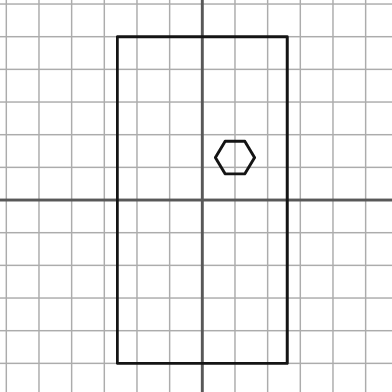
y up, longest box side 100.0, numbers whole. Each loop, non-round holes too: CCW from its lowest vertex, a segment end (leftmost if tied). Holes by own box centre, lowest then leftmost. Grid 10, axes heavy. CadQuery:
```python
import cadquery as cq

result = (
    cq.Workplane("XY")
    .moveTo(-26.0, -50.0)
    .lineTo(26.0, -50.0)
    .lineTo(26.0, 50.0)
    .lineTo(-26.0, 50.0)
    .close()
    .moveTo(7.0, 8.0)
    .lineTo(13.0, 8.0)
    .lineTo(16.0, 13.0)
    .lineTo(13.0, 18.0)
    .lineTo(7.0, 18.0)
    .lineTo(4.0, 13.0)
    .close()
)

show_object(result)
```